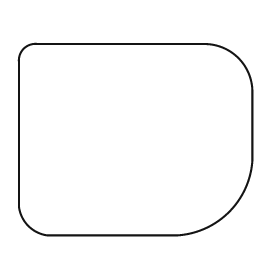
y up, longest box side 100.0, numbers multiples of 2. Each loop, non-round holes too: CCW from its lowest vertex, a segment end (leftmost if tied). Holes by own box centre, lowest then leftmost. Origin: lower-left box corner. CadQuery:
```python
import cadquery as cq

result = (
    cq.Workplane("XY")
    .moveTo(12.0, 0.0)
    .lineTo(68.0, 0.0)
    .threePointArc((90.0, 10.0), (100.0, 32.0))
    .lineTo(100.0, 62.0)
    .threePointArc((94.0, 76.0), (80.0, 82.0))
    .lineTo(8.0, 82.0)
    .threePointArc((2.0, 80.0), (0.0, 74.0))
    .lineTo(0.0, 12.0)
    .threePointArc((4.0, 4.0), (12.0, 0.0))
    .close()
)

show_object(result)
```